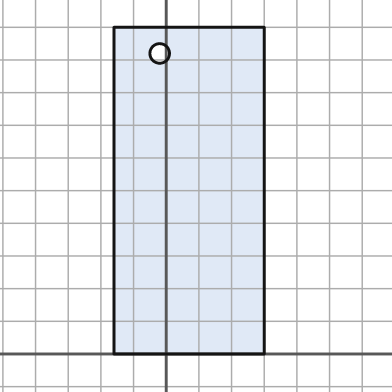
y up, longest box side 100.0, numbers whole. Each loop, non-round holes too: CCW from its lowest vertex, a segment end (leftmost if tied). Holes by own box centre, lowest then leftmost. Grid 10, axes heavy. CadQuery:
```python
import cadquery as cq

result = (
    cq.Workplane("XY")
    .moveTo(-16.0, 0.0)
    .lineTo(30.0, 0.0)
    .lineTo(30.0, 100.0)
    .lineTo(-16.0, 100.0)
    .close()
    .moveTo(-2.0, 92.0)
    .circle(3.0)
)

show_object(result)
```